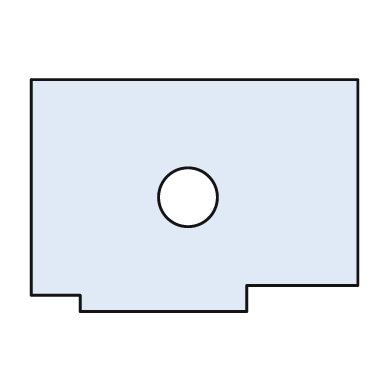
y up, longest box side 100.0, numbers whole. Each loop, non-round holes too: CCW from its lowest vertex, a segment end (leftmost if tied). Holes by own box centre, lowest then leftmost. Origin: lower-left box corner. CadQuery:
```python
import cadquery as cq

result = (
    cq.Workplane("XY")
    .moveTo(15.0, 0.0)
    .lineTo(66.0, 0.0)
    .lineTo(66.0, 8.0)
    .lineTo(100.0, 8.0)
    .lineTo(100.0, 71.0)
    .lineTo(0.0, 71.0)
    .lineTo(0.0, 5.0)
    .lineTo(15.0, 5.0)
    .close()
    .moveTo(48.0, 35.0)
    .circle(9.0)
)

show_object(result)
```